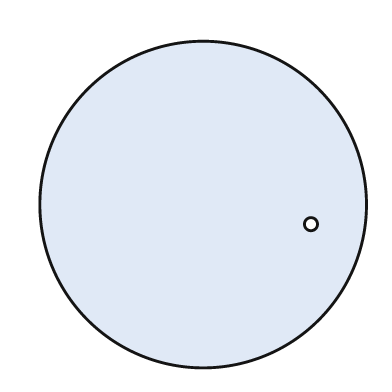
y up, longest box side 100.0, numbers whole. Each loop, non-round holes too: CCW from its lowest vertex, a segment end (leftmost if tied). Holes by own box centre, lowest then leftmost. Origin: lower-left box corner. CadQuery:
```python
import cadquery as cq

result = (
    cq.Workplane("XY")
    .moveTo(50.0, 50.0)
    .circle(50.0)
    .moveTo(83.0, 44.0)
    .circle(2.0)
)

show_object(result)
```